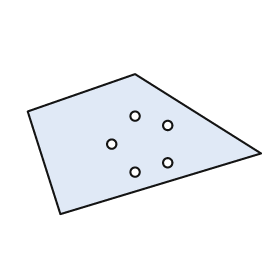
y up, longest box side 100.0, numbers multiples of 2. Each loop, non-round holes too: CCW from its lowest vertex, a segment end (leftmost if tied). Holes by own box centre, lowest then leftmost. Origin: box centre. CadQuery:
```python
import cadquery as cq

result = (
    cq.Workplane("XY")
    .moveTo(-36.0, -30.0)
    .lineTo(50.0, -4.0)
    .lineTo(-4.0, 30.0)
    .lineTo(-50.0, 14.0)
    .close()
    .moveTo(-4.0, -12.0)
    .circle(2.0)
    .moveTo(10.0, -8.0)
    .circle(2.0)
    .moveTo(-14.0, 0.0)
    .circle(2.0)
    .moveTo(10.0, 8.0)
    .circle(2.0)
    .moveTo(-4.0, 12.0)
    .circle(2.0)
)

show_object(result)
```